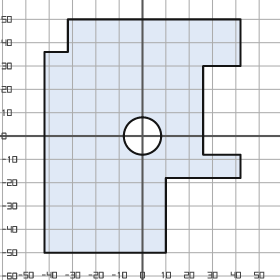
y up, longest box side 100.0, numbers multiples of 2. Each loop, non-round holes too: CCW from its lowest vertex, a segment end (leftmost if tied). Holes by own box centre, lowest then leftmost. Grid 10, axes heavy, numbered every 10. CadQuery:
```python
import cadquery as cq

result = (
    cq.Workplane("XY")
    .moveTo(-42.0, -50.0)
    .lineTo(10.0, -50.0)
    .lineTo(10.0, -18.0)
    .lineTo(42.0, -18.0)
    .lineTo(42.0, -8.0)
    .lineTo(26.0, -8.0)
    .lineTo(26.0, 30.0)
    .lineTo(42.0, 30.0)
    .lineTo(42.0, 50.0)
    .lineTo(-32.0, 50.0)
    .lineTo(-32.0, 36.0)
    .lineTo(-42.0, 36.0)
    .close()
    .moveTo(0.0, 0.0)
    .circle(8.0)
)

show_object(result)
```